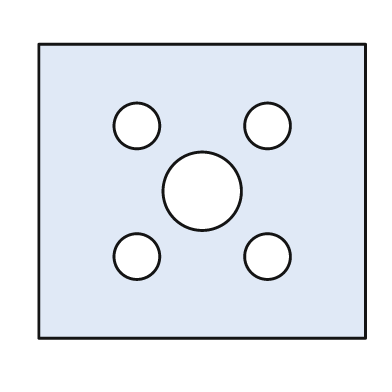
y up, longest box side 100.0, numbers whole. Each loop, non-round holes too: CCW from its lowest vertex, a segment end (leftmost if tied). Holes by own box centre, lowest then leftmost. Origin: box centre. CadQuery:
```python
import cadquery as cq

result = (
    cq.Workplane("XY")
    .moveTo(-50.0, -45.0)
    .lineTo(50.0, -45.0)
    .lineTo(50.0, 45.0)
    .lineTo(-50.0, 45.0)
    .close()
    .moveTo(-20.0, -20.0)
    .circle(7.0)
    .moveTo(20.0, -20.0)
    .circle(7.0)
    .moveTo(0.0, 0.0)
    .circle(12.0)
    .moveTo(-20.0, 20.0)
    .circle(7.0)
    .moveTo(20.0, 20.0)
    .circle(7.0)
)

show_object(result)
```